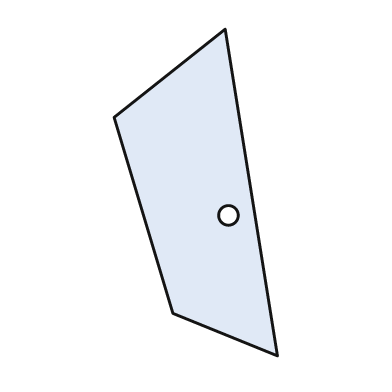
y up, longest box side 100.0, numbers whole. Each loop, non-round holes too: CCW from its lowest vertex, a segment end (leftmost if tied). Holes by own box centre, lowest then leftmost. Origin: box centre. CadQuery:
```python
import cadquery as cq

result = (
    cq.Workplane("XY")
    .moveTo(25.0, -50.0)
    .lineTo(9.0, 50.0)
    .lineTo(-25.0, 23.0)
    .lineTo(-7.0, -37.0)
    .close()
    .moveTo(10.0, -7.0)
    .circle(3.0)
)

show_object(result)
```